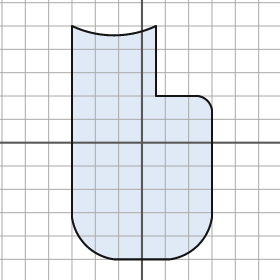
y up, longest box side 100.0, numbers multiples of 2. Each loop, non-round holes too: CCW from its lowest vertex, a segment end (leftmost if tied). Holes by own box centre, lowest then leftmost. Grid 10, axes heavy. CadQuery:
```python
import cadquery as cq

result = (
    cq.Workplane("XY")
    .moveTo(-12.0, -50.0)
    .lineTo(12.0, -50.0)
    .threePointArc((24.0, -44.0), (30.0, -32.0))
    .lineTo(30.0, 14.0)
    .threePointArc((28.0, 18.0), (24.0, 20.0))
    .lineTo(6.0, 20.0)
    .lineTo(6.0, 50.0)
    .threePointArc((-12.0, 46.0), (-30.0, 50.0))
    .lineTo(-30.0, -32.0)
    .threePointArc((-24.0, -44.0), (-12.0, -50.0))
    .close()
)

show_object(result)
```